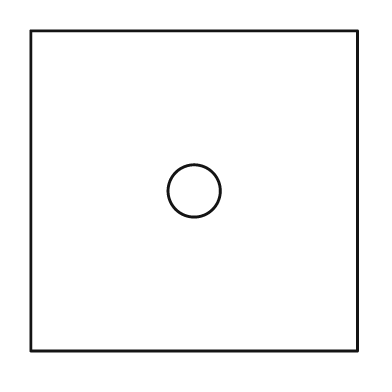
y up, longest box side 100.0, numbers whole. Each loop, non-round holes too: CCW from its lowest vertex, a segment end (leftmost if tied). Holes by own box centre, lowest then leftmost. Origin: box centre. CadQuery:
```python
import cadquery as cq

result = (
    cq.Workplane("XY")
    .moveTo(-50.0, -49.0)
    .lineTo(50.0, -49.0)
    .lineTo(50.0, 49.0)
    .lineTo(-50.0, 49.0)
    .close()
    .moveTo(0.0, 0.0)
    .circle(8.0)
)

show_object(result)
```